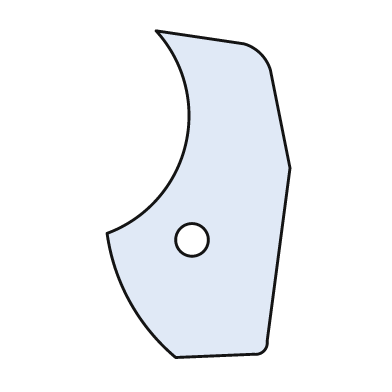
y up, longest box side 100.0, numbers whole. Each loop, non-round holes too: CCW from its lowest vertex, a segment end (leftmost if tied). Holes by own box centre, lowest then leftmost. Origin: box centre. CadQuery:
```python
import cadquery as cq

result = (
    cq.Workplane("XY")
    .moveTo(-7.0, -50.0)
    .lineTo(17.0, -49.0)
    .threePointArc((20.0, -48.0), (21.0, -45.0))
    .lineTo(28.0, 8.0)
    .lineTo(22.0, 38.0)
    .threePointArc((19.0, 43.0), (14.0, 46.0))
    .lineTo(-13.0, 50.0)
    .threePointArc((-4.0, 15.0), (-28.0, -12.0))
    .threePointArc((-21.0, -33.0), (-7.0, -50.0))
    .close()
    .moveTo(-2.0, -14.0)
    .circle(5.0)
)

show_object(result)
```